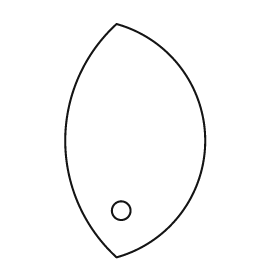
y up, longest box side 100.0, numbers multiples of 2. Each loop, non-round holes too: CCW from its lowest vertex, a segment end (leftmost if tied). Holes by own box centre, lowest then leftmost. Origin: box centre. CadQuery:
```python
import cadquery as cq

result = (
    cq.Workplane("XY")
    .moveTo(-8.0, -50.0)
    .threePointArc((30.0, 0.0), (-8.0, 50.0))
    .threePointArc((-30.0, 0.0), (-8.0, -50.0))
    .close()
    .moveTo(-6.0, -30.0)
    .circle(4.0)
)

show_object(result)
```